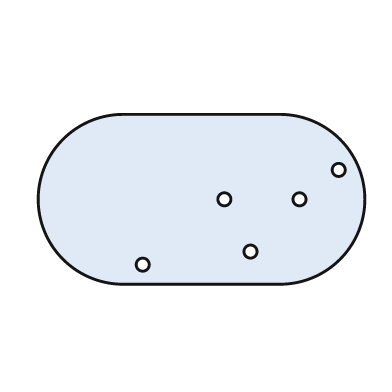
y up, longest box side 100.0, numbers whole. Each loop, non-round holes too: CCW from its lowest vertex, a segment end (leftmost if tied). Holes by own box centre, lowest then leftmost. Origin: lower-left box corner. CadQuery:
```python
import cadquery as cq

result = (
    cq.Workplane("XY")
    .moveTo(26.0, 0.0)
    .lineTo(74.0, 0.0)
    .threePointArc((100.0, 26.0), (74.0, 52.0))
    .lineTo(26.0, 52.0)
    .threePointArc((0.0, 26.0), (26.0, 0.0))
    .close()
    .moveTo(32.0, 6.0)
    .circle(2.0)
    .moveTo(65.0, 10.0)
    .circle(2.0)
    .moveTo(57.0, 26.0)
    .circle(2.0)
    .moveTo(80.0, 26.0)
    .circle(2.0)
    .moveTo(92.0, 35.0)
    .circle(2.0)
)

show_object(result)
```